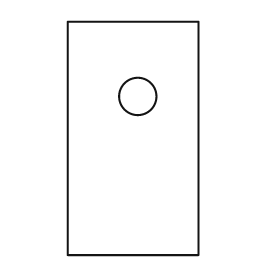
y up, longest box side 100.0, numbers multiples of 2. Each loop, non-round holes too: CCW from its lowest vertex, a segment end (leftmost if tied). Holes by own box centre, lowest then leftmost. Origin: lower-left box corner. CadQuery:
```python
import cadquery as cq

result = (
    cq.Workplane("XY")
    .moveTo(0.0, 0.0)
    .lineTo(56.0, 0.0)
    .lineTo(56.0, 100.0)
    .lineTo(0.0, 100.0)
    .close()
    .moveTo(30.0, 68.0)
    .circle(8.0)
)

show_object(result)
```